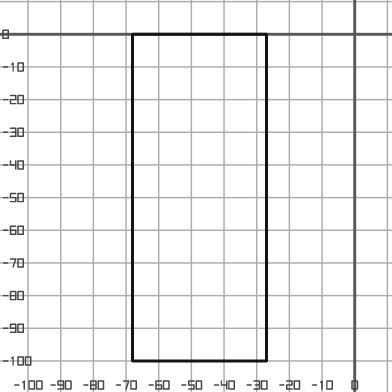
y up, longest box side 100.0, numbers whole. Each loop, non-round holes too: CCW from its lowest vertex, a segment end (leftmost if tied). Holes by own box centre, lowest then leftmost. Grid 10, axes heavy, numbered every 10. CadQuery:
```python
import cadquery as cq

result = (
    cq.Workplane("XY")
    .moveTo(-68.0, -100.0)
    .lineTo(-27.0, -100.0)
    .lineTo(-27.0, 0.0)
    .lineTo(-68.0, 0.0)
    .close()
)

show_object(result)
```